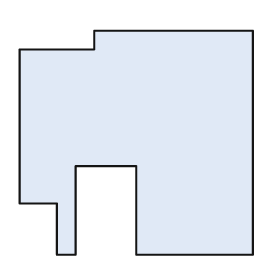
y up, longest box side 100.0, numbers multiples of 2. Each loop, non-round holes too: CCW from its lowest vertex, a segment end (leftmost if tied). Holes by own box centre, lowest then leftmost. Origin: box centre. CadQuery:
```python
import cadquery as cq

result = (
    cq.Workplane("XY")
    .moveTo(-34.0, -48.0)
    .lineTo(-26.0, -48.0)
    .lineTo(-26.0, -10.0)
    .lineTo(0.0, -10.0)
    .lineTo(0.0, -48.0)
    .lineTo(50.0, -48.0)
    .lineTo(50.0, 48.0)
    .lineTo(-18.0, 48.0)
    .lineTo(-18.0, 40.0)
    .lineTo(-50.0, 40.0)
    .lineTo(-50.0, -26.0)
    .lineTo(-34.0, -26.0)
    .close()
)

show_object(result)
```